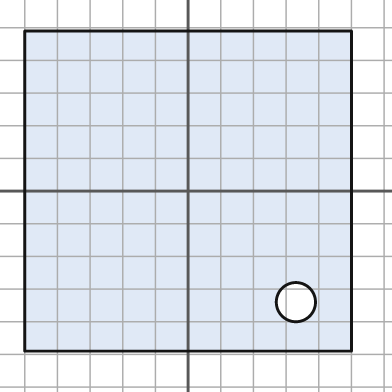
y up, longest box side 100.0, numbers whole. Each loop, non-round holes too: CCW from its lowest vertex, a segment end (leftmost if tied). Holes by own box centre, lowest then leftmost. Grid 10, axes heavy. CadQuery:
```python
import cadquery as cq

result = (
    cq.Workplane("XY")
    .moveTo(-50.0, -49.0)
    .lineTo(50.0, -49.0)
    .lineTo(50.0, 49.0)
    .lineTo(-50.0, 49.0)
    .close()
    .moveTo(33.0, -34.0)
    .circle(6.0)
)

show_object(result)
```